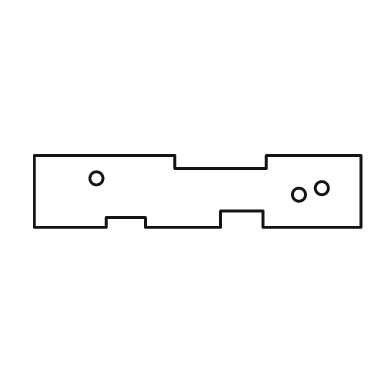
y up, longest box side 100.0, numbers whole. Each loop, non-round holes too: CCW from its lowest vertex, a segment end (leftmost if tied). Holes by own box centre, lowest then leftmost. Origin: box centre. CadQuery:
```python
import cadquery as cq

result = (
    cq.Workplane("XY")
    .moveTo(-50.0, -11.0)
    .lineTo(-28.0, -11.0)
    .lineTo(-28.0, -8.0)
    .lineTo(-16.0, -8.0)
    .lineTo(-16.0, -11.0)
    .lineTo(7.0, -11.0)
    .lineTo(7.0, -6.0)
    .lineTo(20.0, -6.0)
    .lineTo(20.0, -11.0)
    .lineTo(50.0, -11.0)
    .lineTo(50.0, 11.0)
    .lineTo(21.0, 11.0)
    .lineTo(21.0, 7.0)
    .lineTo(-7.0, 7.0)
    .lineTo(-7.0, 11.0)
    .lineTo(-50.0, 11.0)
    .close()
    .moveTo(31.0, -1.0)
    .circle(2.0)
    .moveTo(38.0, 1.0)
    .circle(2.0)
    .moveTo(-31.0, 4.0)
    .circle(2.0)
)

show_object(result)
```